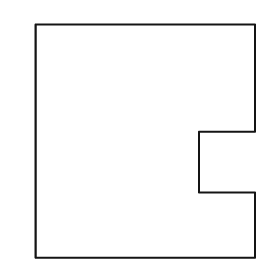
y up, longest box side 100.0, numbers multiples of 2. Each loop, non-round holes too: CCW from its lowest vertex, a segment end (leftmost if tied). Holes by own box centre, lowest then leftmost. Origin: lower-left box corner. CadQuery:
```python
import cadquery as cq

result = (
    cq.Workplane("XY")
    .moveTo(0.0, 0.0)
    .lineTo(94.0, 0.0)
    .lineTo(94.0, 28.0)
    .lineTo(70.0, 28.0)
    .lineTo(70.0, 54.0)
    .lineTo(94.0, 54.0)
    .lineTo(94.0, 100.0)
    .lineTo(0.0, 100.0)
    .close()
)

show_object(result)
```